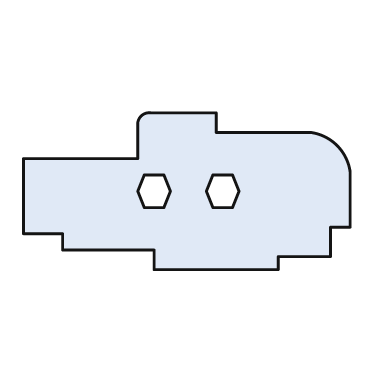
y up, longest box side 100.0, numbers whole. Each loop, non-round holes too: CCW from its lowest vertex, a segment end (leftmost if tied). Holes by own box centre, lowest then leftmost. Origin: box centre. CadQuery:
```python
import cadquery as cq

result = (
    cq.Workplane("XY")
    .moveTo(-10.0, -24.0)
    .lineTo(28.0, -24.0)
    .lineTo(28.0, -20.0)
    .lineTo(44.0, -20.0)
    .lineTo(44.0, -11.0)
    .lineTo(50.0, -11.0)
    .lineTo(50.0, 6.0)
    .threePointArc((46.0, 14.0), (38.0, 18.0))
    .lineTo(9.0, 18.0)
    .lineTo(9.0, 24.0)
    .lineTo(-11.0, 24.0)
    .threePointArc((-14.0, 23.0), (-15.0, 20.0))
    .lineTo(-15.0, 10.0)
    .lineTo(-50.0, 10.0)
    .lineTo(-50.0, -13.0)
    .lineTo(-38.0, -13.0)
    .lineTo(-38.0, -18.0)
    .lineTo(-10.0, -18.0)
    .close()
    .moveTo(-13.0, -5.0)
    .lineTo(-7.0, -5.0)
    .lineTo(-5.0, 0.0)
    .lineTo(-7.0, 5.0)
    .lineTo(-13.0, 5.0)
    .lineTo(-15.0, 0.0)
    .close()
    .moveTo(8.0, -5.0)
    .lineTo(14.0, -5.0)
    .lineTo(16.0, 0.0)
    .lineTo(14.0, 5.0)
    .lineTo(8.0, 5.0)
    .lineTo(6.0, 0.0)
    .close()
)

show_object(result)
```